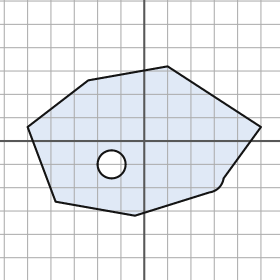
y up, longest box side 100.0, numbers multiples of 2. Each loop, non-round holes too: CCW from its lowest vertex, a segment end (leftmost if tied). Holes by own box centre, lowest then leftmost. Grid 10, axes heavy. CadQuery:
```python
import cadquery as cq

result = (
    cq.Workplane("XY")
    .moveTo(-4.0, -32.0)
    .lineTo(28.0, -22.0)
    .threePointArc((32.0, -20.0), (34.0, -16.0))
    .lineTo(50.0, 6.0)
    .lineTo(10.0, 32.0)
    .lineTo(-24.0, 26.0)
    .lineTo(-50.0, 6.0)
    .lineTo(-38.0, -26.0)
    .close()
    .moveTo(-14.0, -10.0)
    .circle(6.0)
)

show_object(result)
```